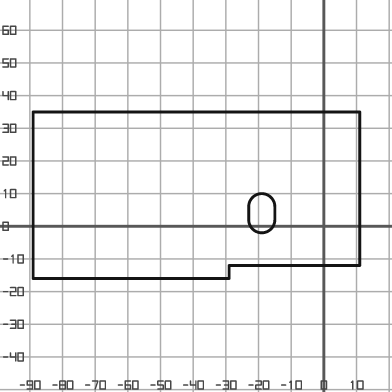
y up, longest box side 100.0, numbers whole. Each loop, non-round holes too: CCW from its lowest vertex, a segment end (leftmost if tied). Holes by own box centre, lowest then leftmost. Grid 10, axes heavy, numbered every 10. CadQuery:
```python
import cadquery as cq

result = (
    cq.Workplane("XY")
    .moveTo(-89.0, -16.0)
    .lineTo(-29.0, -16.0)
    .lineTo(-29.0, -12.0)
    .lineTo(11.0, -12.0)
    .lineTo(11.0, 35.0)
    .lineTo(-89.0, 35.0)
    .close()
    .moveTo(-23.0, 2.0)
    .threePointArc((-19.0, -2.0), (-15.0, 2.0))
    .lineTo(-15.0, 6.0)
    .threePointArc((-19.0, 10.0), (-23.0, 6.0))
    .close()
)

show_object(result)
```